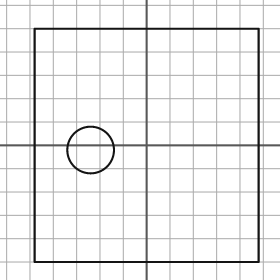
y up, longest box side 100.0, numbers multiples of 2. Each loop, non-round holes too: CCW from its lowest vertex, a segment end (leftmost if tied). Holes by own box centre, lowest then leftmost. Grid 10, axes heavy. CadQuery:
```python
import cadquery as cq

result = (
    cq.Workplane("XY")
    .moveTo(-48.0, -50.0)
    .lineTo(48.0, -50.0)
    .lineTo(48.0, 50.0)
    .lineTo(-48.0, 50.0)
    .close()
    .moveTo(-24.0, -2.0)
    .circle(10.0)
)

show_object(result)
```